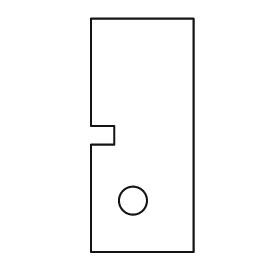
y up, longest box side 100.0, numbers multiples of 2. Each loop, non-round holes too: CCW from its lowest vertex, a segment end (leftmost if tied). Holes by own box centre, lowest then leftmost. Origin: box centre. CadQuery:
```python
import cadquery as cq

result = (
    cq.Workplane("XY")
    .moveTo(-22.0, -50.0)
    .lineTo(22.0, -50.0)
    .lineTo(22.0, 50.0)
    .lineTo(-22.0, 50.0)
    .lineTo(-22.0, 4.0)
    .lineTo(-12.0, 4.0)
    .lineTo(-12.0, -4.0)
    .lineTo(-22.0, -4.0)
    .close()
    .moveTo(-4.0, -28.0)
    .circle(6.0)
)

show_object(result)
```